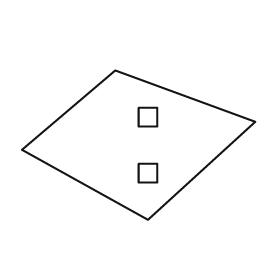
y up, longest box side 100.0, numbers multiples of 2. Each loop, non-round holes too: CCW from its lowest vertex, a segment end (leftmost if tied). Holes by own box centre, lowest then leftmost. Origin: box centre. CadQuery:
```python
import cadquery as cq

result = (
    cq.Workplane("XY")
    .moveTo(4.0, -32.0)
    .lineTo(50.0, 10.0)
    .lineTo(-10.0, 32.0)
    .lineTo(-50.0, -2.0)
    .close()
    .moveTo(0.0, -16.0)
    .lineTo(8.0, -16.0)
    .lineTo(8.0, -8.0)
    .lineTo(0.0, -8.0)
    .close()
    .moveTo(0.0, 8.0)
    .lineTo(8.0, 8.0)
    .lineTo(8.0, 16.0)
    .lineTo(0.0, 16.0)
    .close()
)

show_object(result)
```